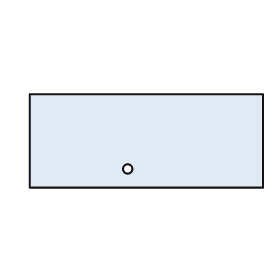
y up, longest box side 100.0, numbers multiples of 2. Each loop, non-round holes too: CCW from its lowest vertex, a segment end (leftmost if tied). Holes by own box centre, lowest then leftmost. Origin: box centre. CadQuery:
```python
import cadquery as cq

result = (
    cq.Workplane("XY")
    .moveTo(-50.0, -20.0)
    .lineTo(50.0, -20.0)
    .lineTo(50.0, 20.0)
    .lineTo(-50.0, 20.0)
    .close()
    .moveTo(-8.0, -12.0)
    .circle(2.0)
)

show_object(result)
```